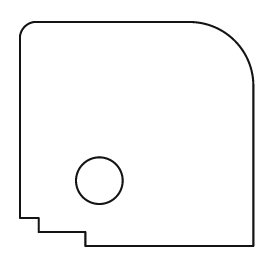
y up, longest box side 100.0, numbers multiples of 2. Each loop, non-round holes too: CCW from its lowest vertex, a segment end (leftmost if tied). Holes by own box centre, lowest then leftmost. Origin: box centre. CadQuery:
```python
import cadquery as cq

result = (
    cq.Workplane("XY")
    .moveTo(-22.0, -48.0)
    .lineTo(50.0, -48.0)
    .lineTo(50.0, 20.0)
    .threePointArc((42.0, 40.0), (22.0, 48.0))
    .lineTo(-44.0, 48.0)
    .threePointArc((-48.0, 46.0), (-50.0, 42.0))
    .lineTo(-50.0, -36.0)
    .lineTo(-42.0, -36.0)
    .lineTo(-42.0, -42.0)
    .lineTo(-22.0, -42.0)
    .close()
    .moveTo(-16.0, -20.0)
    .circle(10.0)
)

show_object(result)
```